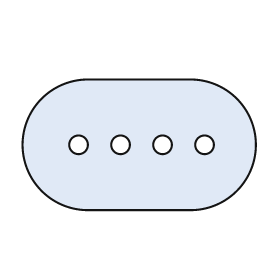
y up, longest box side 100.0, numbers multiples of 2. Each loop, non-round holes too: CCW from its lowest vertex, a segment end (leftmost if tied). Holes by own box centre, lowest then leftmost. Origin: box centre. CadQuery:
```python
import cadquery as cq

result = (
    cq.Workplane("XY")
    .moveTo(-22.0, -28.0)
    .lineTo(22.0, -28.0)
    .threePointArc((50.0, 0.0), (22.0, 28.0))
    .lineTo(-22.0, 28.0)
    .threePointArc((-50.0, 0.0), (-22.0, -28.0))
    .close()
    .moveTo(-26.0, 0.0)
    .circle(4.0)
    .moveTo(-8.0, 0.0)
    .circle(4.0)
    .moveTo(10.0, 0.0)
    .circle(4.0)
    .moveTo(28.0, 0.0)
    .circle(4.0)
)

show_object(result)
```